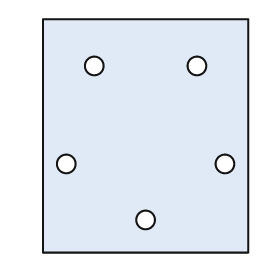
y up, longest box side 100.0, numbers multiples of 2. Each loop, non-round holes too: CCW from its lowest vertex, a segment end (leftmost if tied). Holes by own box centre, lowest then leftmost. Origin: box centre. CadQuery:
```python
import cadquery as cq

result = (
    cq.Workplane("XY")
    .moveTo(-44.0, -50.0)
    .lineTo(44.0, -50.0)
    .lineTo(44.0, 50.0)
    .lineTo(-44.0, 50.0)
    .close()
    .moveTo(0.0, -36.0)
    .circle(4.0)
    .moveTo(-34.0, -12.0)
    .circle(4.0)
    .moveTo(34.0, -12.0)
    .circle(4.0)
    .moveTo(-22.0, 30.0)
    .circle(4.0)
    .moveTo(22.0, 30.0)
    .circle(4.0)
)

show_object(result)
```